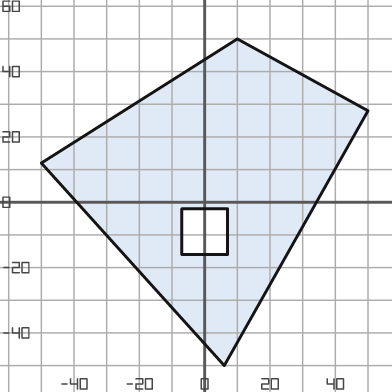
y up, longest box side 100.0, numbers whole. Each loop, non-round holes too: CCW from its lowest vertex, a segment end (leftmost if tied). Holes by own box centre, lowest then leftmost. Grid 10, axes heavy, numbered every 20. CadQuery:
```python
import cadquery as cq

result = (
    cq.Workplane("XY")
    .moveTo(6.0, -50.0)
    .lineTo(50.0, 28.0)
    .lineTo(10.0, 50.0)
    .lineTo(-50.0, 12.0)
    .close()
    .moveTo(-7.0, -16.0)
    .lineTo(7.0, -16.0)
    .lineTo(7.0, -2.0)
    .lineTo(-7.0, -2.0)
    .close()
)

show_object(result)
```